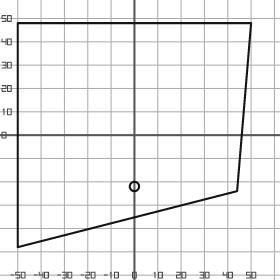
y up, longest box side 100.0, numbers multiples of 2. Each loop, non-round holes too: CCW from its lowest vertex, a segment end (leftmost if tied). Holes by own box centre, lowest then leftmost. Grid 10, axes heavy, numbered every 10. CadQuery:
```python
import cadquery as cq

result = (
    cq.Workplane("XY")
    .moveTo(-50.0, -48.0)
    .lineTo(44.0, -24.0)
    .lineTo(50.0, 48.0)
    .lineTo(-50.0, 48.0)
    .close()
    .moveTo(0.0, -22.0)
    .circle(2.0)
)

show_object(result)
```